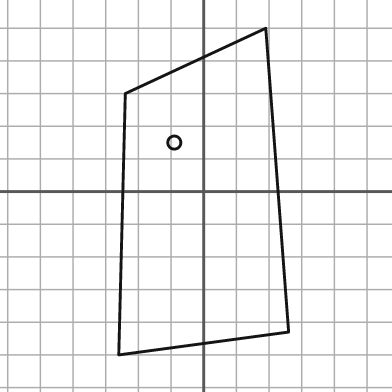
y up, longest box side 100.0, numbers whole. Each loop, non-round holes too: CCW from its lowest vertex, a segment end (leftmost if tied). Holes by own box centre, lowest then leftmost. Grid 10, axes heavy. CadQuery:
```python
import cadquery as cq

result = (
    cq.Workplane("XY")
    .moveTo(-26.0, -50.0)
    .lineTo(26.0, -43.0)
    .lineTo(19.0, 50.0)
    .lineTo(-24.0, 30.0)
    .close()
    .moveTo(-9.0, 15.0)
    .circle(2.0)
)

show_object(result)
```